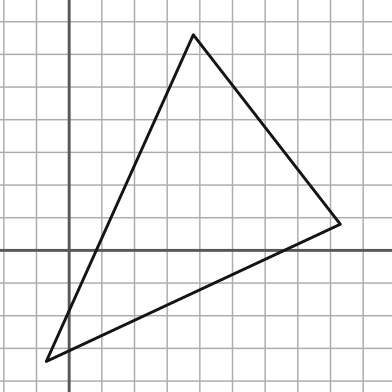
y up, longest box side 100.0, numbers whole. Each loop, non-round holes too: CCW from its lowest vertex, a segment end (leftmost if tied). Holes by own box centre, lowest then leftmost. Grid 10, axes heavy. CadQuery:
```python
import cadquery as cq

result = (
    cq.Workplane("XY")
    .moveTo(-7.0, -34.0)
    .lineTo(83.0, 8.0)
    .lineTo(38.0, 66.0)
    .close()
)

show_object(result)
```